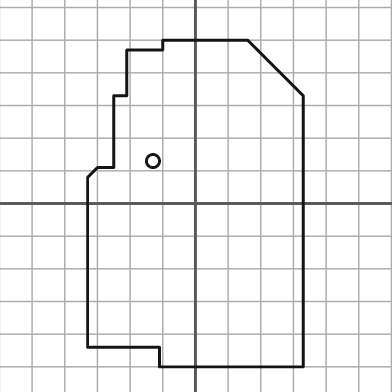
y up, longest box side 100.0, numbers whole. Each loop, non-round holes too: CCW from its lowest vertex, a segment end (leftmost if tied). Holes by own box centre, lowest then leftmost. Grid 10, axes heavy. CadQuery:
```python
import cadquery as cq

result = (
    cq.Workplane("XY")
    .moveTo(-11.0, -50.0)
    .lineTo(33.0, -50.0)
    .lineTo(33.0, 33.0)
    .lineTo(16.0, 50.0)
    .lineTo(-10.0, 50.0)
    .lineTo(-10.0, 47.0)
    .lineTo(-21.0, 47.0)
    .lineTo(-21.0, 33.0)
    .lineTo(-25.0, 33.0)
    .lineTo(-25.0, 11.0)
    .lineTo(-30.0, 11.0)
    .lineTo(-33.0, 8.0)
    .lineTo(-33.0, -44.0)
    .lineTo(-11.0, -44.0)
    .close()
    .moveTo(-13.0, 13.0)
    .circle(2.0)
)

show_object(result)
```